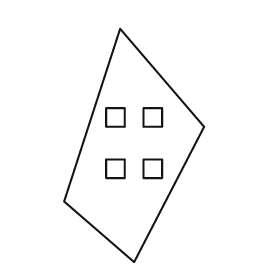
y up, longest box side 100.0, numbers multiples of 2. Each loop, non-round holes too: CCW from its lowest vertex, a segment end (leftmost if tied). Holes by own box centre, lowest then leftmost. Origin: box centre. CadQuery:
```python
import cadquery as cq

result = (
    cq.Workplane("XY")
    .moveTo(0.0, -50.0)
    .lineTo(30.0, 8.0)
    .lineTo(-6.0, 50.0)
    .lineTo(-30.0, -24.0)
    .close()
    .moveTo(-12.0, -14.0)
    .lineTo(-4.0, -14.0)
    .lineTo(-4.0, -6.0)
    .lineTo(-12.0, -6.0)
    .close()
    .moveTo(4.0, -14.0)
    .lineTo(12.0, -14.0)
    .lineTo(12.0, -6.0)
    .lineTo(4.0, -6.0)
    .close()
    .moveTo(-12.0, 8.0)
    .lineTo(-4.0, 8.0)
    .lineTo(-4.0, 16.0)
    .lineTo(-12.0, 16.0)
    .close()
    .moveTo(4.0, 8.0)
    .lineTo(12.0, 8.0)
    .lineTo(12.0, 16.0)
    .lineTo(4.0, 16.0)
    .close()
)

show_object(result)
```